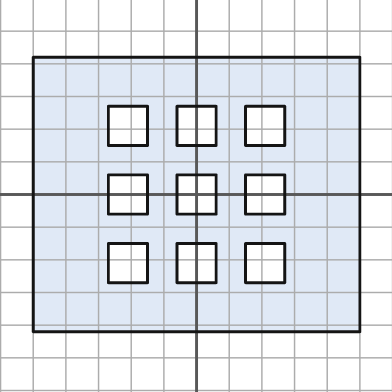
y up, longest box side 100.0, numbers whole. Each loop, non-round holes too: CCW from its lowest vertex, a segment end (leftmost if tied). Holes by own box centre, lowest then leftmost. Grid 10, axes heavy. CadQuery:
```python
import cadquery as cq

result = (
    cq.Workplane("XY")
    .moveTo(-50.0, -42.0)
    .lineTo(50.0, -42.0)
    .lineTo(50.0, 42.0)
    .lineTo(-50.0, 42.0)
    .close()
    .moveTo(-27.0, -27.0)
    .lineTo(-15.0, -27.0)
    .lineTo(-15.0, -15.0)
    .lineTo(-27.0, -15.0)
    .close()
    .moveTo(-6.0, -27.0)
    .lineTo(6.0, -27.0)
    .lineTo(6.0, -15.0)
    .lineTo(-6.0, -15.0)
    .close()
    .moveTo(15.0, -27.0)
    .lineTo(27.0, -27.0)
    .lineTo(27.0, -15.0)
    .lineTo(15.0, -15.0)
    .close()
    .moveTo(-27.0, -6.0)
    .lineTo(-15.0, -6.0)
    .lineTo(-15.0, 6.0)
    .lineTo(-27.0, 6.0)
    .close()
    .moveTo(-6.0, -6.0)
    .lineTo(6.0, -6.0)
    .lineTo(6.0, 6.0)
    .lineTo(-6.0, 6.0)
    .close()
    .moveTo(15.0, -6.0)
    .lineTo(27.0, -6.0)
    .lineTo(27.0, 6.0)
    .lineTo(15.0, 6.0)
    .close()
    .moveTo(-27.0, 15.0)
    .lineTo(-15.0, 15.0)
    .lineTo(-15.0, 27.0)
    .lineTo(-27.0, 27.0)
    .close()
    .moveTo(-6.0, 15.0)
    .lineTo(6.0, 15.0)
    .lineTo(6.0, 27.0)
    .lineTo(-6.0, 27.0)
    .close()
    .moveTo(15.0, 15.0)
    .lineTo(27.0, 15.0)
    .lineTo(27.0, 27.0)
    .lineTo(15.0, 27.0)
    .close()
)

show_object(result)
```